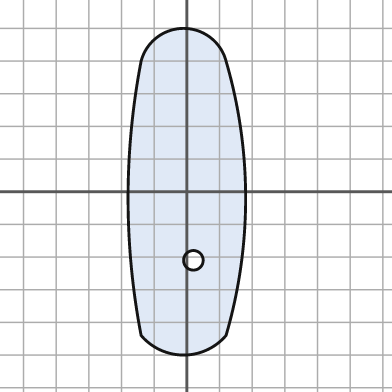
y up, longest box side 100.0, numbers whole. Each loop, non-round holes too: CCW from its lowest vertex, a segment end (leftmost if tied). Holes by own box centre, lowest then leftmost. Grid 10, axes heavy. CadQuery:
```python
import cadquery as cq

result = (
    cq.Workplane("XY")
    .moveTo(-14.0, -44.0)
    .threePointArc((-1.0, -50.0), (12.0, -44.0))
    .threePointArc((18.0, -2.0), (12.0, 40.0))
    .threePointArc((-1.0, 50.0), (-14.0, 40.0))
    .threePointArc((-18.0, -2.0), (-14.0, -44.0))
    .close()
    .moveTo(2.0, -21.0)
    .circle(3.0)
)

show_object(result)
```